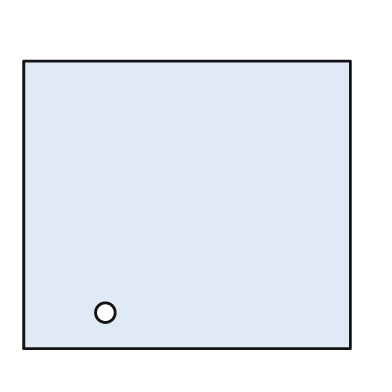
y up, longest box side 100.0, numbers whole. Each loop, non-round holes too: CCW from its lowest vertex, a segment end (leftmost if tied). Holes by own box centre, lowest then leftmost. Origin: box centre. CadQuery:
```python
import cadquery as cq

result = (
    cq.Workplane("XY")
    .moveTo(-50.0, -44.0)
    .lineTo(50.0, -44.0)
    .lineTo(50.0, 44.0)
    .lineTo(-50.0, 44.0)
    .close()
    .moveTo(-25.0, -33.0)
    .circle(3.0)
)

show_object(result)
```